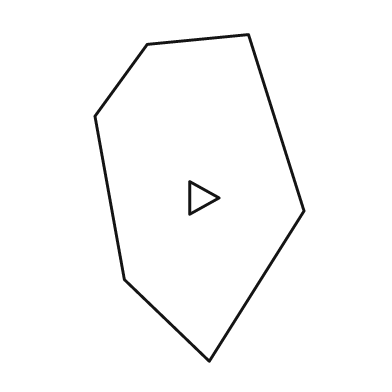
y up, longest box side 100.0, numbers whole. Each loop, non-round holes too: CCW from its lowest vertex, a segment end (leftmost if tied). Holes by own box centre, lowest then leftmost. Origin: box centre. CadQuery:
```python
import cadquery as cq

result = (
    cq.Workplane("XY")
    .moveTo(3.0, -50.0)
    .lineTo(32.0, -4.0)
    .lineTo(15.0, 50.0)
    .lineTo(-16.0, 47.0)
    .lineTo(-32.0, 25.0)
    .lineTo(-23.0, -25.0)
    .close()
    .moveTo(-3.0, -5.0)
    .lineTo(6.0, 0.0)
    .lineTo(-3.0, 5.0)
    .close()
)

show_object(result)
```